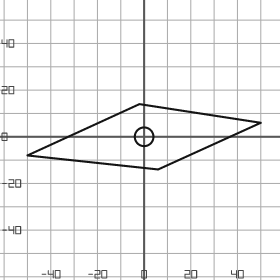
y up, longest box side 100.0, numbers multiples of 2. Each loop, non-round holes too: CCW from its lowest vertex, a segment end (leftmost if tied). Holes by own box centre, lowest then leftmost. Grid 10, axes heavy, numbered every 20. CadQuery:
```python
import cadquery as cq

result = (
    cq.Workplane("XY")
    .moveTo(6.0, -14.0)
    .lineTo(50.0, 6.0)
    .lineTo(-2.0, 14.0)
    .lineTo(-50.0, -8.0)
    .close()
    .moveTo(0.0, 0.0)
    .circle(4.0)
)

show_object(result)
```